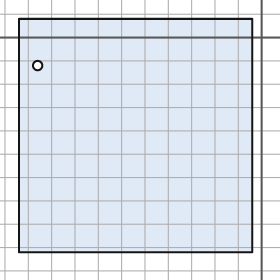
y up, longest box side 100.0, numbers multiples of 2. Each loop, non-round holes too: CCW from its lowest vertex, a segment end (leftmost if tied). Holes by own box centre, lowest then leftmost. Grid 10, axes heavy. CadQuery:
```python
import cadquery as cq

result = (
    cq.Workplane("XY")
    .moveTo(-104.0, -92.0)
    .lineTo(-4.0, -92.0)
    .lineTo(-4.0, 8.0)
    .lineTo(-104.0, 8.0)
    .close()
    .moveTo(-96.0, -12.0)
    .circle(2.0)
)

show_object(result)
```